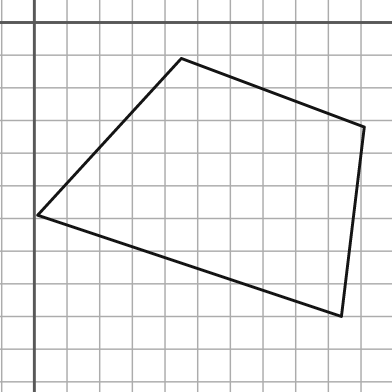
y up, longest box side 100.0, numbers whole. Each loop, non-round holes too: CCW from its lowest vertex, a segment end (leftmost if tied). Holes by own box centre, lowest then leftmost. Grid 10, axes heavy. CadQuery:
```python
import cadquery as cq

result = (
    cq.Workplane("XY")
    .moveTo(94.0, -90.0)
    .lineTo(101.0, -32.0)
    .lineTo(45.0, -11.0)
    .lineTo(1.0, -59.0)
    .close()
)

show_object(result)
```